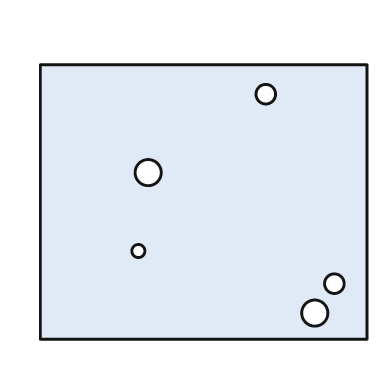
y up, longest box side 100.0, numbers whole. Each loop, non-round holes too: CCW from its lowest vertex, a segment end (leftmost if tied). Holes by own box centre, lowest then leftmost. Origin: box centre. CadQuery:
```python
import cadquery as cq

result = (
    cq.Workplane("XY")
    .moveTo(-50.0, -42.0)
    .lineTo(50.0, -42.0)
    .lineTo(50.0, 42.0)
    .lineTo(-50.0, 42.0)
    .close()
    .moveTo(34.0, -34.0)
    .circle(4.0)
    .moveTo(40.0, -25.0)
    .circle(3.0)
    .moveTo(-20.0, -15.0)
    .circle(2.0)
    .moveTo(-17.0, 9.0)
    .circle(4.0)
    .moveTo(19.0, 33.0)
    .circle(3.0)
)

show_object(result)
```